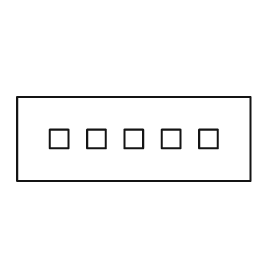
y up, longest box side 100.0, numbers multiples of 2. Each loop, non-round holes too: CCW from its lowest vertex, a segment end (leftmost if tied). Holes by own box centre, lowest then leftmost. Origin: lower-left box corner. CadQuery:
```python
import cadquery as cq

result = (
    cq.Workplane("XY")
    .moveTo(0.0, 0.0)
    .lineTo(100.0, 0.0)
    .lineTo(100.0, 36.0)
    .lineTo(0.0, 36.0)
    .close()
    .moveTo(14.0, 14.0)
    .lineTo(22.0, 14.0)
    .lineTo(22.0, 22.0)
    .lineTo(14.0, 22.0)
    .close()
    .moveTo(30.0, 14.0)
    .lineTo(38.0, 14.0)
    .lineTo(38.0, 22.0)
    .lineTo(30.0, 22.0)
    .close()
    .moveTo(46.0, 14.0)
    .lineTo(54.0, 14.0)
    .lineTo(54.0, 22.0)
    .lineTo(46.0, 22.0)
    .close()
    .moveTo(62.0, 14.0)
    .lineTo(70.0, 14.0)
    .lineTo(70.0, 22.0)
    .lineTo(62.0, 22.0)
    .close()
    .moveTo(78.0, 14.0)
    .lineTo(86.0, 14.0)
    .lineTo(86.0, 22.0)
    .lineTo(78.0, 22.0)
    .close()
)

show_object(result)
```